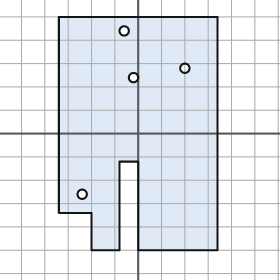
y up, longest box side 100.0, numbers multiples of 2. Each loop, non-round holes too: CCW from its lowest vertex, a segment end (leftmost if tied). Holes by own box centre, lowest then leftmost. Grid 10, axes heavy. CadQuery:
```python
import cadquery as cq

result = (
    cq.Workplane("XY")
    .moveTo(-20.0, -50.0)
    .lineTo(-8.0, -50.0)
    .lineTo(-8.0, -12.0)
    .lineTo(0.0, -12.0)
    .lineTo(0.0, -50.0)
    .lineTo(34.0, -50.0)
    .lineTo(34.0, 50.0)
    .lineTo(-34.0, 50.0)
    .lineTo(-34.0, -34.0)
    .lineTo(-20.0, -34.0)
    .close()
    .moveTo(-24.0, -26.0)
    .circle(2.0)
    .moveTo(-2.0, 24.0)
    .circle(2.0)
    .moveTo(20.0, 28.0)
    .circle(2.0)
    .moveTo(-6.0, 44.0)
    .circle(2.0)
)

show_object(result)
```